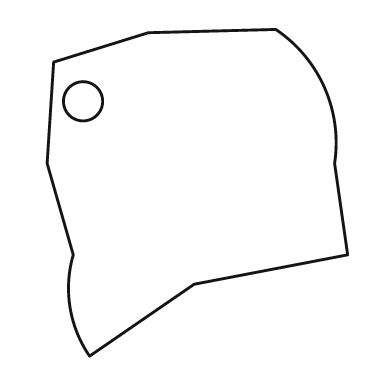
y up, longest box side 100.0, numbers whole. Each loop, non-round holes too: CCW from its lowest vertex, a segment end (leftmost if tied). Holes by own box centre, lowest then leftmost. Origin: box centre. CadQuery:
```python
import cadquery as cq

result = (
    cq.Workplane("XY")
    .moveTo(-33.0, -50.0)
    .lineTo(-1.0, -28.0)
    .lineTo(46.0, -19.0)
    .lineTo(42.0, 9.0)
    .threePointArc((39.0, 32.0), (24.0, 50.0))
    .lineTo(-15.0, 49.0)
    .lineTo(-44.0, 40.0)
    .lineTo(-46.0, 9.0)
    .lineTo(-38.0, -19.0)
    .threePointArc((-39.0, -35.0), (-33.0, -50.0))
    .close()
    .moveTo(-35.0, 28.0)
    .circle(6.0)
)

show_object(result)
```